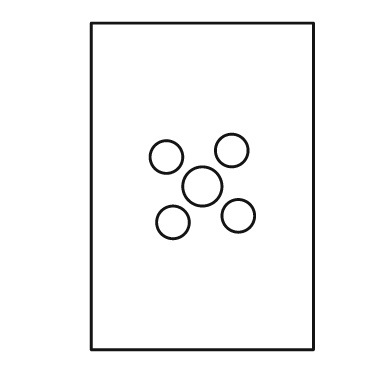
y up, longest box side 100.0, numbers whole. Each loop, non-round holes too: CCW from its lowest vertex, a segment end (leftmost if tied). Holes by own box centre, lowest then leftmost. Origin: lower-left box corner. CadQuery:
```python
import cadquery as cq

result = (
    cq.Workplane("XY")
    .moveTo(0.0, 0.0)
    .lineTo(68.0, 0.0)
    .lineTo(68.0, 100.0)
    .lineTo(0.0, 100.0)
    .close()
    .moveTo(25.0, 39.0)
    .circle(5.0)
    .moveTo(45.0, 41.0)
    .circle(5.0)
    .moveTo(34.0, 50.0)
    .circle(6.0)
    .moveTo(23.0, 59.0)
    .circle(5.0)
    .moveTo(43.0, 61.0)
    .circle(5.0)
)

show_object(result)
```